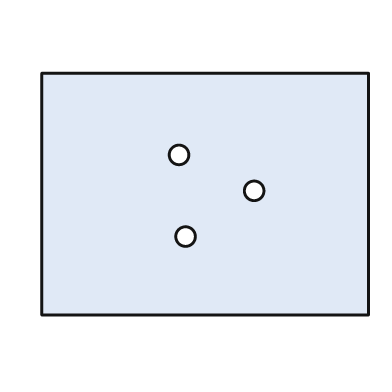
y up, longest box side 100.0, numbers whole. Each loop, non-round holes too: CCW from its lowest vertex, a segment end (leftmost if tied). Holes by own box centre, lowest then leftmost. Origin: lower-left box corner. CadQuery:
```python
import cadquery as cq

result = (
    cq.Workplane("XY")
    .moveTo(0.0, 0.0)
    .lineTo(100.0, 0.0)
    .lineTo(100.0, 74.0)
    .lineTo(0.0, 74.0)
    .close()
    .moveTo(44.0, 24.0)
    .circle(3.0)
    .moveTo(65.0, 38.0)
    .circle(3.0)
    .moveTo(42.0, 49.0)
    .circle(3.0)
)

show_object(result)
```